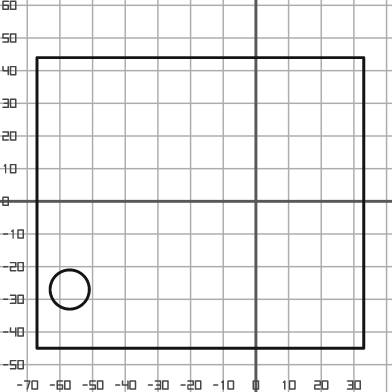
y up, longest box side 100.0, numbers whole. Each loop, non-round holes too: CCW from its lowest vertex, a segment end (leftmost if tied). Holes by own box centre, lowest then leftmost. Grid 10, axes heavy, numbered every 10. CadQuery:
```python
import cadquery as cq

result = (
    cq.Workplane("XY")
    .moveTo(-67.0, -45.0)
    .lineTo(33.0, -45.0)
    .lineTo(33.0, 44.0)
    .lineTo(-67.0, 44.0)
    .close()
    .moveTo(-57.0, -27.0)
    .circle(6.0)
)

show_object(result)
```